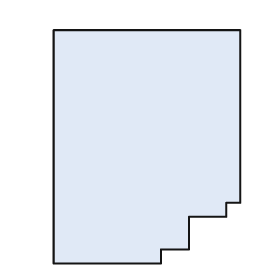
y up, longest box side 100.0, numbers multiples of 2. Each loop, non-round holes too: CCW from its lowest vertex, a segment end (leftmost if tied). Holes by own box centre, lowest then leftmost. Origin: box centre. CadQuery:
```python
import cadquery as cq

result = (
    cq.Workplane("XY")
    .moveTo(-40.0, -50.0)
    .lineTo(6.0, -50.0)
    .lineTo(6.0, -44.0)
    .lineTo(18.0, -44.0)
    .lineTo(18.0, -30.0)
    .lineTo(34.0, -30.0)
    .lineTo(34.0, -24.0)
    .lineTo(40.0, -24.0)
    .lineTo(40.0, 50.0)
    .lineTo(-40.0, 50.0)
    .close()
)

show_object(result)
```